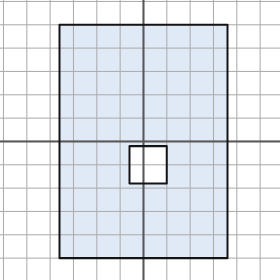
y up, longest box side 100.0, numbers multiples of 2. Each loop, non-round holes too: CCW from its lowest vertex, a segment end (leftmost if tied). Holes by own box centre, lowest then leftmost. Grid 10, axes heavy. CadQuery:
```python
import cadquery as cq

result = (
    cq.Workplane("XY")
    .moveTo(-36.0, -50.0)
    .lineTo(36.0, -50.0)
    .lineTo(36.0, 50.0)
    .lineTo(-36.0, 50.0)
    .close()
    .moveTo(-6.0, -18.0)
    .lineTo(10.0, -18.0)
    .lineTo(10.0, -2.0)
    .lineTo(-6.0, -2.0)
    .close()
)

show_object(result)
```